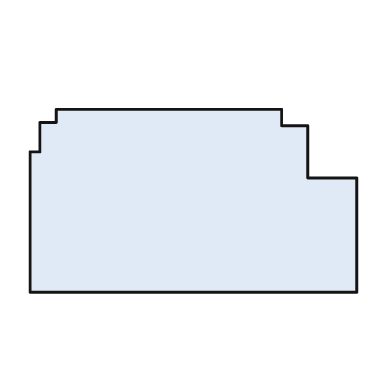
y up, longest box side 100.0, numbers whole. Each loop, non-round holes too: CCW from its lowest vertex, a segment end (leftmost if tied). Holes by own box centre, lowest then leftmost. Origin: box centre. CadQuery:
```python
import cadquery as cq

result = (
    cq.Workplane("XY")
    .moveTo(-50.0, -28.0)
    .lineTo(50.0, -28.0)
    .lineTo(50.0, 7.0)
    .lineTo(35.0, 7.0)
    .lineTo(35.0, 23.0)
    .lineTo(27.0, 23.0)
    .lineTo(27.0, 28.0)
    .lineTo(-42.0, 28.0)
    .lineTo(-42.0, 24.0)
    .lineTo(-47.0, 24.0)
    .lineTo(-47.0, 15.0)
    .lineTo(-50.0, 15.0)
    .close()
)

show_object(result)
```